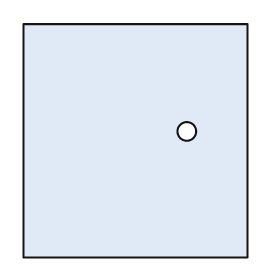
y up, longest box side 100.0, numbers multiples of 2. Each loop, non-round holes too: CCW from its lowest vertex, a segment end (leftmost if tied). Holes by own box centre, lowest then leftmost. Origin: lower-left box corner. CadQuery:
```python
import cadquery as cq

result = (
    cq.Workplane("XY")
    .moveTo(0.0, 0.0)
    .lineTo(96.0, 0.0)
    .lineTo(96.0, 100.0)
    .lineTo(0.0, 100.0)
    .close()
    .moveTo(70.0, 54.0)
    .circle(4.0)
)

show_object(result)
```